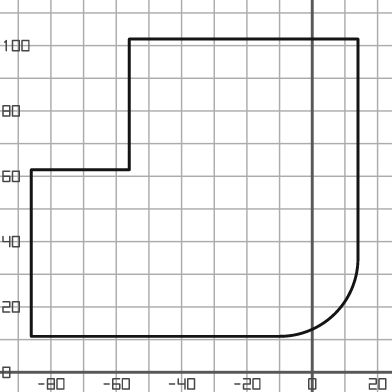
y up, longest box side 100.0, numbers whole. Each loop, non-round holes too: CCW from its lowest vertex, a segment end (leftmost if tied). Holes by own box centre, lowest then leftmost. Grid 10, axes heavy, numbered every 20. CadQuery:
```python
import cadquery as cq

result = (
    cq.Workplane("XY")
    .moveTo(-86.0, 11.0)
    .lineTo(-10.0, 11.0)
    .threePointArc((7.0, 18.0), (14.0, 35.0))
    .lineTo(14.0, 102.0)
    .lineTo(-56.0, 102.0)
    .lineTo(-56.0, 62.0)
    .lineTo(-86.0, 62.0)
    .close()
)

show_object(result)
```